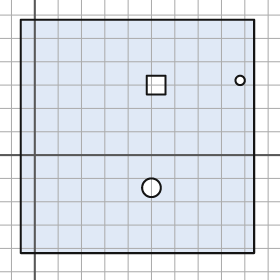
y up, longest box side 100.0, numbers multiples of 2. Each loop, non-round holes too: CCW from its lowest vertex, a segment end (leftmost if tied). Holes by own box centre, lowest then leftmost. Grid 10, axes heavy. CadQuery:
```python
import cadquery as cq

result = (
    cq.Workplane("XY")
    .moveTo(-6.0, -42.0)
    .lineTo(94.0, -42.0)
    .lineTo(94.0, 58.0)
    .lineTo(-6.0, 58.0)
    .close()
    .moveTo(50.0, -14.0)
    .circle(4.0)
    .moveTo(48.0, 26.0)
    .lineTo(56.0, 26.0)
    .lineTo(56.0, 34.0)
    .lineTo(48.0, 34.0)
    .close()
    .moveTo(88.0, 32.0)
    .circle(2.0)
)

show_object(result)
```